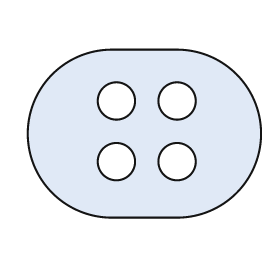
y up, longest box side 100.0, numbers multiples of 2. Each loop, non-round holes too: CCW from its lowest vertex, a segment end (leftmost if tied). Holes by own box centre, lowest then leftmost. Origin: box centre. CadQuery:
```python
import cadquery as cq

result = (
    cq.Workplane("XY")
    .moveTo(-14.0, -36.0)
    .lineTo(14.0, -36.0)
    .threePointArc((50.0, 0.0), (14.0, 36.0))
    .lineTo(-14.0, 36.0)
    .threePointArc((-50.0, 0.0), (-14.0, -36.0))
    .close()
    .moveTo(-12.0, -12.0)
    .circle(8.0)
    .moveTo(14.0, -12.0)
    .circle(8.0)
    .moveTo(-12.0, 14.0)
    .circle(8.0)
    .moveTo(14.0, 14.0)
    .circle(8.0)
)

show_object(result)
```